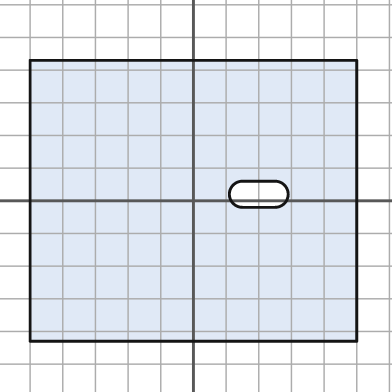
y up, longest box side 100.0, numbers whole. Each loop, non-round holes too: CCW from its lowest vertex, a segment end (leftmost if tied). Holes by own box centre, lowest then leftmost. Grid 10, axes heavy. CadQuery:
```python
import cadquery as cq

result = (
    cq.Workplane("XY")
    .moveTo(-50.0, -43.0)
    .lineTo(50.0, -43.0)
    .lineTo(50.0, 43.0)
    .lineTo(-50.0, 43.0)
    .close()
    .moveTo(15.0, -2.0)
    .lineTo(25.0, -2.0)
    .threePointArc((29.0, 2.0), (25.0, 6.0))
    .lineTo(15.0, 6.0)
    .threePointArc((11.0, 2.0), (15.0, -2.0))
    .close()
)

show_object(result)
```